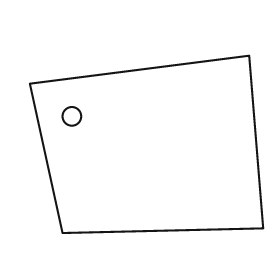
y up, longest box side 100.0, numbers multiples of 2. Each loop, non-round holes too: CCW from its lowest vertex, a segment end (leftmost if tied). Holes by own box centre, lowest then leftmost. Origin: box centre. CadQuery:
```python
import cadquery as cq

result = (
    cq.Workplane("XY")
    .moveTo(-36.0, -38.0)
    .lineTo(50.0, -36.0)
    .lineTo(44.0, 38.0)
    .lineTo(-50.0, 26.0)
    .close()
    .moveTo(-32.0, 12.0)
    .circle(4.0)
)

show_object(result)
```